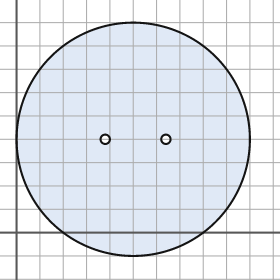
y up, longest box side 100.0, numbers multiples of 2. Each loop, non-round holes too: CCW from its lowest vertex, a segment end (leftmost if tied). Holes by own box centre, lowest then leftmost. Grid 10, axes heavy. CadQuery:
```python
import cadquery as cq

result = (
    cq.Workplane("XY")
    .moveTo(50.0, 40.0)
    .circle(50.0)
    .moveTo(38.0, 40.0)
    .circle(2.0)
    .moveTo(64.0, 40.0)
    .circle(2.0)
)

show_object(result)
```